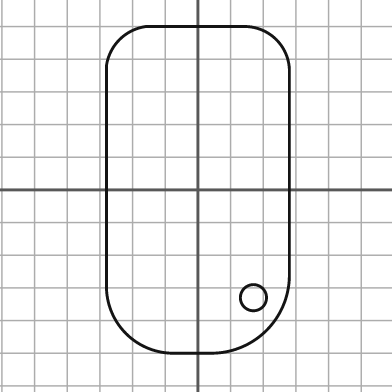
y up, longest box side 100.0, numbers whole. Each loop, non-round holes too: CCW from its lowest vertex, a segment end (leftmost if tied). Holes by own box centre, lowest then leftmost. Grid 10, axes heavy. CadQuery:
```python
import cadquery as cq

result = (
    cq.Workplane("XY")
    .moveTo(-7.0, -50.0)
    .lineTo(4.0, -50.0)
    .threePointArc((21.0, -43.0), (28.0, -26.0))
    .lineTo(28.0, 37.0)
    .threePointArc((24.0, 46.0), (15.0, 50.0))
    .lineTo(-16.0, 50.0)
    .threePointArc((-24.0, 46.0), (-28.0, 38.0))
    .lineTo(-28.0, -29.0)
    .threePointArc((-22.0, -44.0), (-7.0, -50.0))
    .close()
    .moveTo(17.0, -33.0)
    .circle(4.0)
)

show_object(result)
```